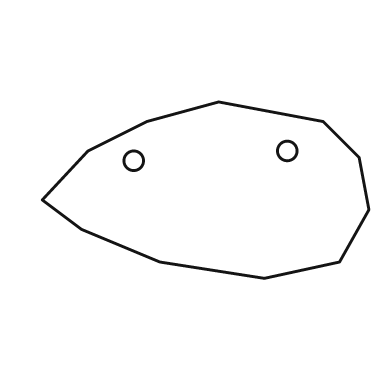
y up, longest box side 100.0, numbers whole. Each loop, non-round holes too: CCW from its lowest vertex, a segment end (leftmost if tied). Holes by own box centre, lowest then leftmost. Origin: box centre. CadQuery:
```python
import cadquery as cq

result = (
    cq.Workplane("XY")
    .moveTo(18.0, -27.0)
    .lineTo(41.0, -22.0)
    .lineTo(50.0, -6.0)
    .lineTo(47.0, 10.0)
    .lineTo(36.0, 21.0)
    .lineTo(4.0, 27.0)
    .lineTo(-18.0, 21.0)
    .lineTo(-36.0, 12.0)
    .lineTo(-50.0, -3.0)
    .lineTo(-38.0, -12.0)
    .lineTo(-14.0, -22.0)
    .close()
    .moveTo(-22.0, 9.0)
    .circle(3.0)
    .moveTo(25.0, 12.0)
    .circle(3.0)
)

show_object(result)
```